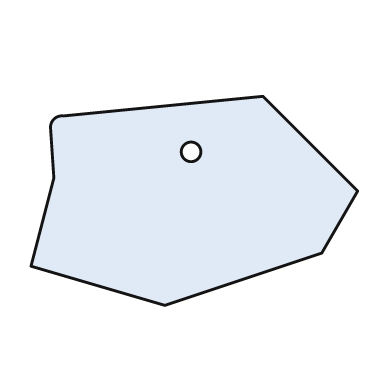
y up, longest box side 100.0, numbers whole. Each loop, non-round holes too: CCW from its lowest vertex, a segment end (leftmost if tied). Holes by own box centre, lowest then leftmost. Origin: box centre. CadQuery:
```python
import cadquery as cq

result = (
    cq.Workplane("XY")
    .moveTo(-9.0, -32.0)
    .lineTo(39.0, -16.0)
    .lineTo(50.0, 3.0)
    .lineTo(21.0, 32.0)
    .lineTo(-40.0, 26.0)
    .threePointArc((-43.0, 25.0), (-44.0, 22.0))
    .lineTo(-43.0, 7.0)
    .lineTo(-50.0, -20.0)
    .close()
    .moveTo(-1.0, 15.0)
    .circle(3.0)
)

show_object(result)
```